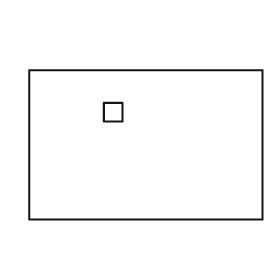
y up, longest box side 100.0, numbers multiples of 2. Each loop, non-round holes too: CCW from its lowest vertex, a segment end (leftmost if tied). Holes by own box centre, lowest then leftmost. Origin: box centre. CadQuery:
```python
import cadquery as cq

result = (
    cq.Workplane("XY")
    .moveTo(-50.0, -32.0)
    .lineTo(50.0, -32.0)
    .lineTo(50.0, 32.0)
    .lineTo(-50.0, 32.0)
    .close()
    .moveTo(-18.0, 10.0)
    .lineTo(-10.0, 10.0)
    .lineTo(-10.0, 18.0)
    .lineTo(-18.0, 18.0)
    .close()
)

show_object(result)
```